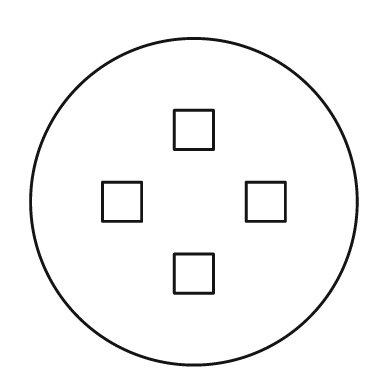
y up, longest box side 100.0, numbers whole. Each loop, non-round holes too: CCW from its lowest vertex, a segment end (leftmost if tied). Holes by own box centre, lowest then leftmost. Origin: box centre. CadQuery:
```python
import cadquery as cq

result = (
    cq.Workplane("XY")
    .moveTo(0.0, 0.0)
    .circle(50.0)
    .moveTo(-6.0, -28.0)
    .lineTo(6.0, -28.0)
    .lineTo(6.0, -16.0)
    .lineTo(-6.0, -16.0)
    .close()
    .moveTo(-28.0, -6.0)
    .lineTo(-16.0, -6.0)
    .lineTo(-16.0, 6.0)
    .lineTo(-28.0, 6.0)
    .close()
    .moveTo(16.0, -6.0)
    .lineTo(28.0, -6.0)
    .lineTo(28.0, 6.0)
    .lineTo(16.0, 6.0)
    .close()
    .moveTo(-6.0, 16.0)
    .lineTo(6.0, 16.0)
    .lineTo(6.0, 28.0)
    .lineTo(-6.0, 28.0)
    .close()
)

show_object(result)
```